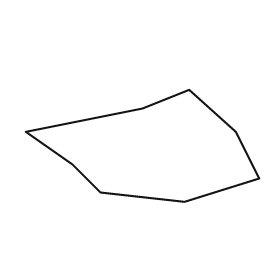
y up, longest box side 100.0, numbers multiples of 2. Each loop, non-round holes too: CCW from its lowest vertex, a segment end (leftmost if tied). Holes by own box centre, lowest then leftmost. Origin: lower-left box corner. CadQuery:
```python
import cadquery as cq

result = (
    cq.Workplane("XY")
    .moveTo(68.0, 0.0)
    .lineTo(100.0, 10.0)
    .lineTo(90.0, 30.0)
    .lineTo(70.0, 48.0)
    .lineTo(50.0, 40.0)
    .lineTo(0.0, 30.0)
    .lineTo(20.0, 16.0)
    .lineTo(32.0, 4.0)
    .close()
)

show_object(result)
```